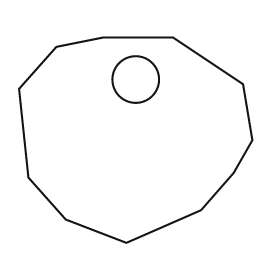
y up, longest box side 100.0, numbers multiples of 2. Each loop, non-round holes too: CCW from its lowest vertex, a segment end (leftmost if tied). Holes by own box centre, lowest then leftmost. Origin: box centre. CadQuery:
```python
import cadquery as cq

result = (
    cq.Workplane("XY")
    .moveTo(-4.0, -44.0)
    .lineTo(28.0, -30.0)
    .lineTo(42.0, -14.0)
    .lineTo(50.0, 0.0)
    .lineTo(46.0, 24.0)
    .lineTo(16.0, 44.0)
    .lineTo(-14.0, 44.0)
    .lineTo(-34.0, 40.0)
    .lineTo(-50.0, 22.0)
    .lineTo(-46.0, -16.0)
    .lineTo(-30.0, -34.0)
    .close()
    .moveTo(0.0, 26.0)
    .circle(10.0)
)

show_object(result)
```